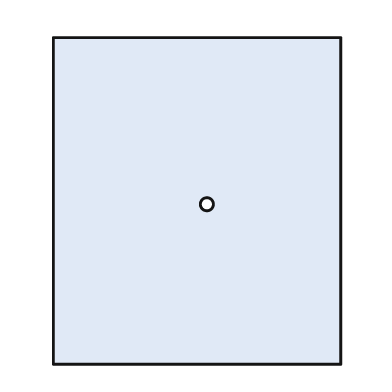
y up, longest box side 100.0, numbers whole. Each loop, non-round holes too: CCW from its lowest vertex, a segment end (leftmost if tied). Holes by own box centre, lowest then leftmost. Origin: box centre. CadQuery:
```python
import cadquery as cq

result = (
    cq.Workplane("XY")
    .moveTo(-44.0, -50.0)
    .lineTo(44.0, -50.0)
    .lineTo(44.0, 50.0)
    .lineTo(-44.0, 50.0)
    .close()
    .moveTo(3.0, -1.0)
    .circle(2.0)
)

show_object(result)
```